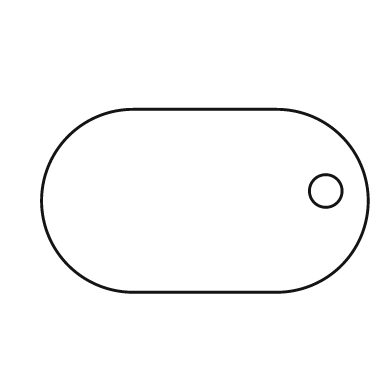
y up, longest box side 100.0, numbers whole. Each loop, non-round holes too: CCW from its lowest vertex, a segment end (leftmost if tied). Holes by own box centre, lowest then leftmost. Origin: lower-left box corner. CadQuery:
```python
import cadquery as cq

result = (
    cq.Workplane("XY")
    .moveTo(28.0, 0.0)
    .lineTo(72.0, 0.0)
    .threePointArc((100.0, 28.0), (72.0, 56.0))
    .lineTo(28.0, 56.0)
    .threePointArc((0.0, 28.0), (28.0, 0.0))
    .close()
    .moveTo(87.0, 31.0)
    .circle(5.0)
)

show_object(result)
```